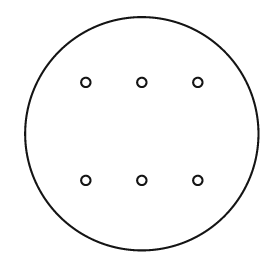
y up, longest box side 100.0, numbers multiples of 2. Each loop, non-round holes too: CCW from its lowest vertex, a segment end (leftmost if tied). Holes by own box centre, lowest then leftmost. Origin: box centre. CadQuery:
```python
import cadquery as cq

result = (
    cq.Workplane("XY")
    .moveTo(0.0, 0.0)
    .circle(50.0)
    .moveTo(-24.0, -20.0)
    .circle(2.0)
    .moveTo(0.0, -20.0)
    .circle(2.0)
    .moveTo(24.0, -20.0)
    .circle(2.0)
    .moveTo(-24.0, 22.0)
    .circle(2.0)
    .moveTo(0.0, 22.0)
    .circle(2.0)
    .moveTo(24.0, 22.0)
    .circle(2.0)
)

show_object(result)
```